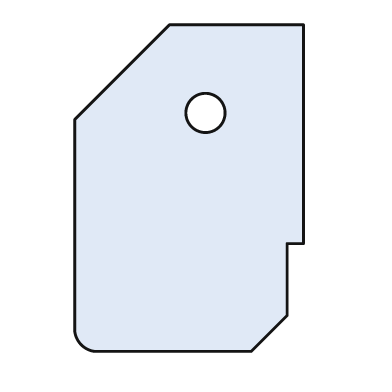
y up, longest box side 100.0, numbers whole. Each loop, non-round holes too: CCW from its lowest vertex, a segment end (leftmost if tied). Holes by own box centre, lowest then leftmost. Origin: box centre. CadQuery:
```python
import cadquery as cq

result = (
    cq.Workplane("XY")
    .moveTo(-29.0, -50.0)
    .lineTo(19.0, -50.0)
    .lineTo(30.0, -39.0)
    .lineTo(30.0, -17.0)
    .lineTo(35.0, -17.0)
    .lineTo(35.0, 50.0)
    .lineTo(-6.0, 50.0)
    .lineTo(-35.0, 21.0)
    .lineTo(-35.0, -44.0)
    .threePointArc((-33.0, -48.0), (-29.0, -50.0))
    .close()
    .moveTo(5.0, 23.0)
    .circle(6.0)
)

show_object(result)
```